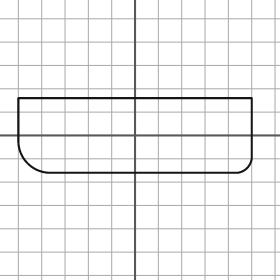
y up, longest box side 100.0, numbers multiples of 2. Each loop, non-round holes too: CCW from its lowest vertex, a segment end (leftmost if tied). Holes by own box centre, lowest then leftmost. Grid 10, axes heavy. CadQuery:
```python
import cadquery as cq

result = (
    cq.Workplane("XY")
    .moveTo(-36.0, -16.0)
    .lineTo(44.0, -16.0)
    .threePointArc((48.0, -14.0), (50.0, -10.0))
    .lineTo(50.0, 16.0)
    .lineTo(-50.0, 16.0)
    .lineTo(-50.0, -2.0)
    .threePointArc((-46.0, -12.0), (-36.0, -16.0))
    .close()
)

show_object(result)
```